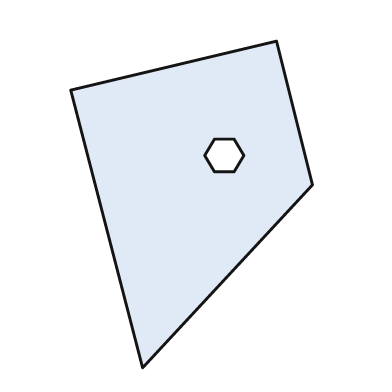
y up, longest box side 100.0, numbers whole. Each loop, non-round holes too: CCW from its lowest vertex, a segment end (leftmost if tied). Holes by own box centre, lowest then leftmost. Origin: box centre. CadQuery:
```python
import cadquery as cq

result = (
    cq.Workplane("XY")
    .moveTo(-15.0, -50.0)
    .lineTo(37.0, 6.0)
    .lineTo(26.0, 50.0)
    .lineTo(-37.0, 35.0)
    .close()
    .moveTo(7.0, 10.0)
    .lineTo(13.0, 10.0)
    .lineTo(16.0, 15.0)
    .lineTo(13.0, 20.0)
    .lineTo(7.0, 20.0)
    .lineTo(4.0, 15.0)
    .close()
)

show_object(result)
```